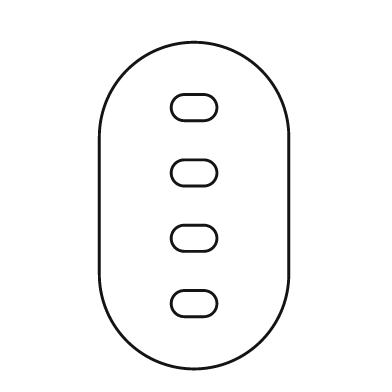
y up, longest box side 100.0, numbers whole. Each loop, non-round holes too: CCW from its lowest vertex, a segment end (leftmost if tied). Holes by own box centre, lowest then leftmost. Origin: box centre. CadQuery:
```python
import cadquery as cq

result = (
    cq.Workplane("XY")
    .moveTo(-29.0, -21.0)
    .threePointArc((0.0, -50.0), (29.0, -21.0))
    .lineTo(29.0, 21.0)
    .threePointArc((0.0, 50.0), (-29.0, 21.0))
    .close()
    .moveTo(-3.0, -34.0)
    .lineTo(3.0, -34.0)
    .threePointArc((7.0, -30.0), (3.0, -26.0))
    .lineTo(-3.0, -26.0)
    .threePointArc((-7.0, -30.0), (-3.0, -34.0))
    .close()
    .moveTo(-3.0, -14.0)
    .lineTo(3.0, -14.0)
    .threePointArc((7.0, -10.0), (3.0, -6.0))
    .lineTo(-3.0, -6.0)
    .threePointArc((-7.0, -10.0), (-3.0, -14.0))
    .close()
    .moveTo(-3.0, 6.0)
    .lineTo(3.0, 6.0)
    .threePointArc((7.0, 10.0), (3.0, 14.0))
    .lineTo(-3.0, 14.0)
    .threePointArc((-7.0, 10.0), (-3.0, 6.0))
    .close()
    .moveTo(-3.0, 26.0)
    .lineTo(3.0, 26.0)
    .threePointArc((7.0, 30.0), (3.0, 34.0))
    .lineTo(-3.0, 34.0)
    .threePointArc((-7.0, 30.0), (-3.0, 26.0))
    .close()
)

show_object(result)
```